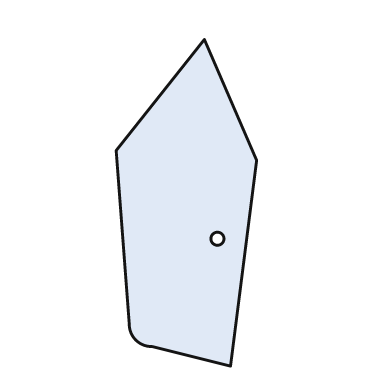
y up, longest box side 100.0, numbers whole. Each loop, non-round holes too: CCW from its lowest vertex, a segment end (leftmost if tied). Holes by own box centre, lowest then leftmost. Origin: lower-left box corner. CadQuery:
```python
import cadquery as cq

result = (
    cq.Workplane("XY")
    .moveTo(35.0, 0.0)
    .lineTo(43.0, 63.0)
    .lineTo(27.0, 100.0)
    .lineTo(0.0, 66.0)
    .lineTo(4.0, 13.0)
    .threePointArc((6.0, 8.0), (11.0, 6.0))
    .close()
    .moveTo(31.0, 39.0)
    .circle(2.0)
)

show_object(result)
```